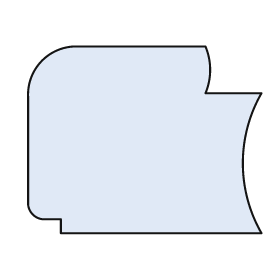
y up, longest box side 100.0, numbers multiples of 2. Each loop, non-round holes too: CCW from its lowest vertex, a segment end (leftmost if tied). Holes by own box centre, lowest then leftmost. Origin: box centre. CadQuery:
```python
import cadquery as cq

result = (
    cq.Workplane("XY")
    .moveTo(-36.0, -40.0)
    .lineTo(50.0, -40.0)
    .threePointArc((42.0, -10.0), (50.0, 20.0))
    .lineTo(26.0, 20.0)
    .threePointArc((28.0, 30.0), (26.0, 40.0))
    .lineTo(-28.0, 40.0)
    .threePointArc((-44.0, 34.0), (-50.0, 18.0))
    .lineTo(-50.0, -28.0)
    .threePointArc((-48.0, -32.0), (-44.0, -34.0))
    .lineTo(-36.0, -34.0)
    .close()
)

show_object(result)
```